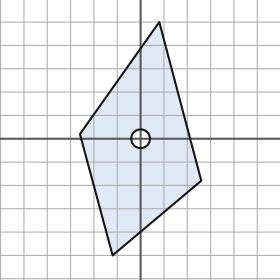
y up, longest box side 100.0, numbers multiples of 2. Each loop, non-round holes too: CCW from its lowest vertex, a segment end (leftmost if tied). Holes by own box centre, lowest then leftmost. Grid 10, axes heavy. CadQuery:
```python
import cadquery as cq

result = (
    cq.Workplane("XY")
    .moveTo(-12.0, -50.0)
    .lineTo(26.0, -18.0)
    .lineTo(8.0, 50.0)
    .lineTo(-26.0, 2.0)
    .close()
    .moveTo(0.0, 0.0)
    .circle(4.0)
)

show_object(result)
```